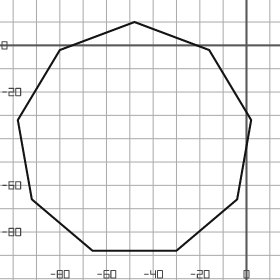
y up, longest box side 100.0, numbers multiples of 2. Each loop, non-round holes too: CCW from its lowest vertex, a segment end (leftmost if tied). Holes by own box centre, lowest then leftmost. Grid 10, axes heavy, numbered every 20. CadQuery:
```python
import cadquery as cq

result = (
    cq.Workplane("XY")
    .moveTo(-66.0, -88.0)
    .lineTo(-30.0, -88.0)
    .lineTo(-4.0, -66.0)
    .lineTo(2.0, -32.0)
    .lineTo(-16.0, -2.0)
    .lineTo(-48.0, 10.0)
    .lineTo(-80.0, -2.0)
    .lineTo(-98.0, -32.0)
    .lineTo(-92.0, -66.0)
    .close()
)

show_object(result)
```